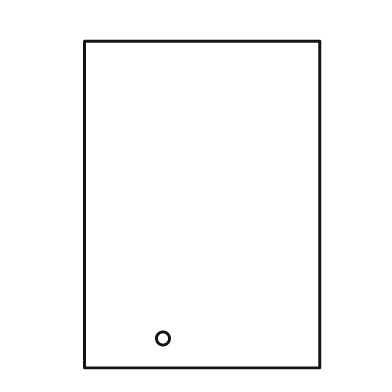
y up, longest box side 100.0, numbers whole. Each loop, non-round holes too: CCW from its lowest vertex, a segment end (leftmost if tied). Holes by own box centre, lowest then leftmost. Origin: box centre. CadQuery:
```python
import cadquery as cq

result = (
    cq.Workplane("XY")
    .moveTo(-36.0, -50.0)
    .lineTo(36.0, -50.0)
    .lineTo(36.0, 50.0)
    .lineTo(-36.0, 50.0)
    .close()
    .moveTo(-12.0, -41.0)
    .circle(2.0)
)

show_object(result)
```